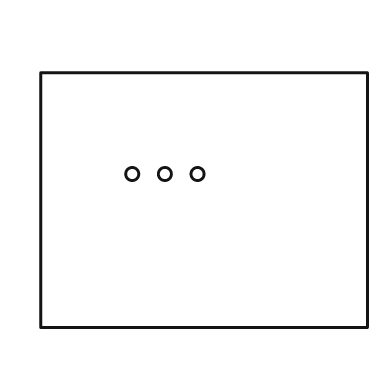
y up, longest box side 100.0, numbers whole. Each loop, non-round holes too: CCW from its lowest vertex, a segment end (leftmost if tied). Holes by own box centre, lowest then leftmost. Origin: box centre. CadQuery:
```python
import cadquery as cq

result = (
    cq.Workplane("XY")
    .moveTo(-50.0, -39.0)
    .lineTo(50.0, -39.0)
    .lineTo(50.0, 39.0)
    .lineTo(-50.0, 39.0)
    .close()
    .moveTo(-22.0, 8.0)
    .circle(2.0)
    .moveTo(-12.0, 8.0)
    .circle(2.0)
    .moveTo(-2.0, 8.0)
    .circle(2.0)
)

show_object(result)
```